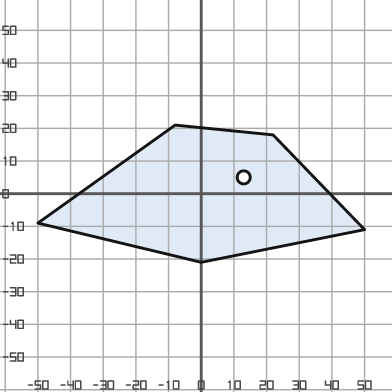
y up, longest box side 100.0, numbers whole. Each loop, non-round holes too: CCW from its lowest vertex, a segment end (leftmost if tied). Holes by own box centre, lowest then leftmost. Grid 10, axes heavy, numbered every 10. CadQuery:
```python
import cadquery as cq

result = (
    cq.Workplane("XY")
    .moveTo(0.0, -21.0)
    .lineTo(50.0, -11.0)
    .lineTo(22.0, 18.0)
    .lineTo(-8.0, 21.0)
    .lineTo(-50.0, -9.0)
    .close()
    .moveTo(13.0, 5.0)
    .circle(2.0)
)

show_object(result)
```